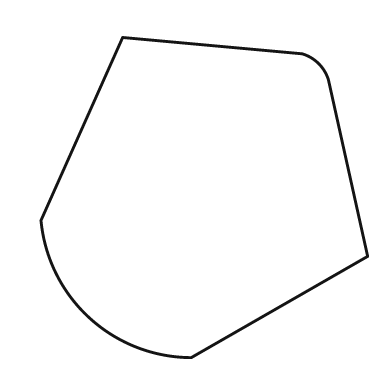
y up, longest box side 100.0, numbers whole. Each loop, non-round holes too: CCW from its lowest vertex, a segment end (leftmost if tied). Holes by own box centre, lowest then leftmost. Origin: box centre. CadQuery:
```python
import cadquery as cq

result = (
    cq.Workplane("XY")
    .moveTo(-4.0, -49.0)
    .lineTo(50.0, -18.0)
    .lineTo(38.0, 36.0)
    .threePointArc((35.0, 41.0), (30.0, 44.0))
    .lineTo(-25.0, 49.0)
    .lineTo(-50.0, -7.0)
    .threePointArc((-35.0, -37.0), (-4.0, -49.0))
    .close()
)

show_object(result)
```